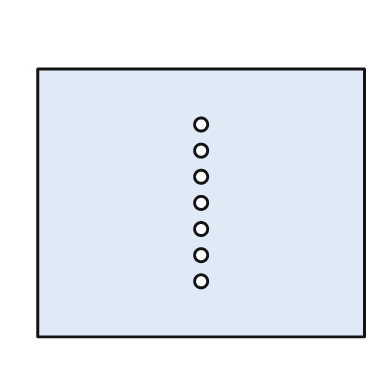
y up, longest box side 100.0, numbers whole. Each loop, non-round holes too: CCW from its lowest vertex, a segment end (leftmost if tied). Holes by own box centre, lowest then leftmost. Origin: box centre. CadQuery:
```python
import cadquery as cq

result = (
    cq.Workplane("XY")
    .moveTo(-50.0, -41.0)
    .lineTo(50.0, -41.0)
    .lineTo(50.0, 41.0)
    .lineTo(-50.0, 41.0)
    .close()
    .moveTo(0.0, -24.0)
    .circle(2.0)
    .moveTo(0.0, -16.0)
    .circle(2.0)
    .moveTo(0.0, -8.0)
    .circle(2.0)
    .moveTo(0.0, 0.0)
    .circle(2.0)
    .moveTo(0.0, 8.0)
    .circle(2.0)
    .moveTo(0.0, 16.0)
    .circle(2.0)
    .moveTo(0.0, 24.0)
    .circle(2.0)
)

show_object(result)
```